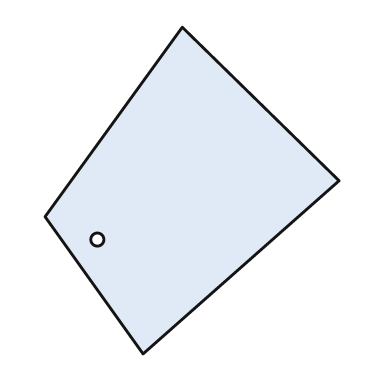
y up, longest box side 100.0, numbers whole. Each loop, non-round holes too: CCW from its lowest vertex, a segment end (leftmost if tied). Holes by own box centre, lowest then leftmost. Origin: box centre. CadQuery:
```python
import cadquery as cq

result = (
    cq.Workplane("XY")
    .moveTo(-15.0, -50.0)
    .lineTo(45.0, 3.0)
    .lineTo(-3.0, 50.0)
    .lineTo(-45.0, -8.0)
    .close()
    .moveTo(-29.0, -15.0)
    .circle(2.0)
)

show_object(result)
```